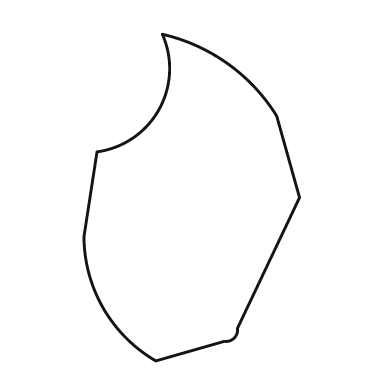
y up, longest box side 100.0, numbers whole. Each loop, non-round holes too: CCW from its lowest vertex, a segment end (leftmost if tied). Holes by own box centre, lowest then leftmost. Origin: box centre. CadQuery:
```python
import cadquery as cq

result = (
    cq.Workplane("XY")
    .moveTo(-11.0, -50.0)
    .lineTo(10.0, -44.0)
    .threePointArc((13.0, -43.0), (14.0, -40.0))
    .lineTo(33.0, 0.0)
    .lineTo(26.0, 25.0)
    .threePointArc((11.0, 41.0), (-9.0, 50.0))
    .threePointArc((-10.0, 27.0), (-29.0, 14.0))
    .lineTo(-33.0, -12.0)
    .threePointArc((-27.0, -34.0), (-11.0, -50.0))
    .close()
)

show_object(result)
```